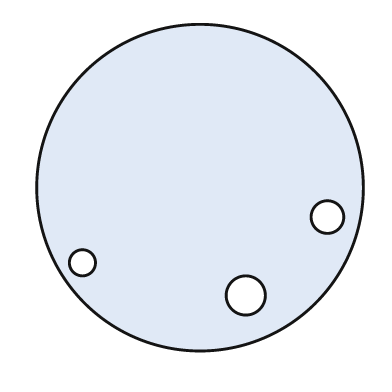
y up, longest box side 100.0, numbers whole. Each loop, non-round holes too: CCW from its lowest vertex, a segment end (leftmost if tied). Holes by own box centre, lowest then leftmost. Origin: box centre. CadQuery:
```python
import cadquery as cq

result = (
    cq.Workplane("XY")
    .moveTo(0.0, 0.0)
    .circle(50.0)
    .moveTo(14.0, -33.0)
    .circle(6.0)
    .moveTo(-36.0, -23.0)
    .circle(4.0)
    .moveTo(39.0, -9.0)
    .circle(5.0)
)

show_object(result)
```